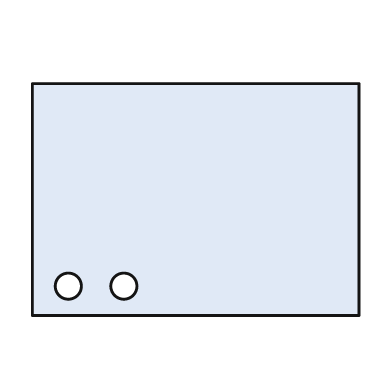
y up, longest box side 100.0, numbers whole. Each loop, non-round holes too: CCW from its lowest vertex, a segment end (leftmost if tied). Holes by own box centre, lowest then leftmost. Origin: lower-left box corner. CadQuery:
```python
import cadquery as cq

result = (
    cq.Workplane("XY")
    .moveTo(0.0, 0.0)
    .lineTo(100.0, 0.0)
    .lineTo(100.0, 71.0)
    .lineTo(0.0, 71.0)
    .close()
    .moveTo(11.0, 9.0)
    .circle(4.0)
    .moveTo(28.0, 9.0)
    .circle(4.0)
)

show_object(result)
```